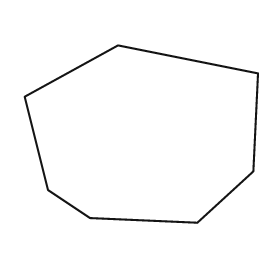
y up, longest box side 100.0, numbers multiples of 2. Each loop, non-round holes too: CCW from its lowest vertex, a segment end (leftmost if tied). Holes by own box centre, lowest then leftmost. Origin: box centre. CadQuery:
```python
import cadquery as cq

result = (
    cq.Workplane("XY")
    .moveTo(24.0, -38.0)
    .lineTo(48.0, -16.0)
    .lineTo(50.0, 26.0)
    .lineTo(-10.0, 38.0)
    .lineTo(-50.0, 16.0)
    .lineTo(-40.0, -24.0)
    .lineTo(-22.0, -36.0)
    .close()
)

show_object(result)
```